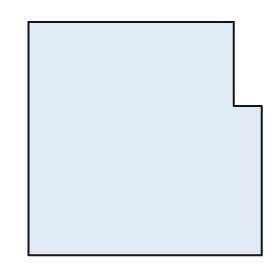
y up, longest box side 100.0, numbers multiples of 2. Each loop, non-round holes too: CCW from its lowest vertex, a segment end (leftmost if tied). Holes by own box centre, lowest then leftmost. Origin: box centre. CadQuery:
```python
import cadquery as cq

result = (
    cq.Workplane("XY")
    .moveTo(-50.0, -50.0)
    .lineTo(50.0, -50.0)
    .lineTo(50.0, 14.0)
    .lineTo(38.0, 14.0)
    .lineTo(38.0, 50.0)
    .lineTo(-50.0, 50.0)
    .close()
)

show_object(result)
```